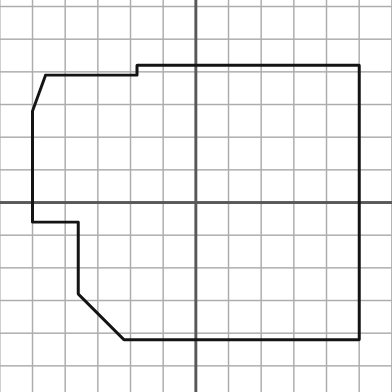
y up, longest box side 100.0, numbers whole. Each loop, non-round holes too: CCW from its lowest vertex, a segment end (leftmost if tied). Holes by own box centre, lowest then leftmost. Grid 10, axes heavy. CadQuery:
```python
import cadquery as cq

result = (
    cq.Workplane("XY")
    .moveTo(-22.0, -42.0)
    .lineTo(50.0, -42.0)
    .lineTo(50.0, 42.0)
    .lineTo(-18.0, 42.0)
    .lineTo(-18.0, 39.0)
    .lineTo(-46.0, 39.0)
    .lineTo(-50.0, 28.0)
    .lineTo(-50.0, -6.0)
    .lineTo(-36.0, -6.0)
    .lineTo(-36.0, -28.0)
    .close()
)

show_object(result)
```